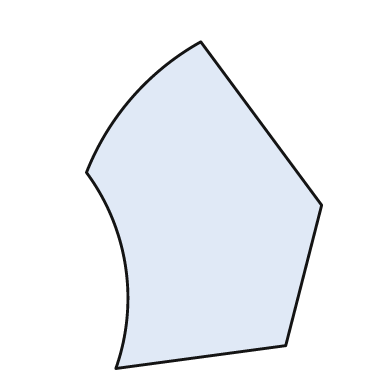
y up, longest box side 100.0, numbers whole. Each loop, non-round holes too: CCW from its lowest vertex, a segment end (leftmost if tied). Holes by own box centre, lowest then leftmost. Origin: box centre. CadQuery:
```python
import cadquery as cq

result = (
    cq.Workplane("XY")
    .moveTo(-27.0, -50.0)
    .lineTo(25.0, -43.0)
    .lineTo(36.0, 0.0)
    .lineTo(-1.0, 50.0)
    .threePointArc((-22.0, 33.0), (-36.0, 10.0))
    .threePointArc((-24.0, -19.0), (-27.0, -50.0))
    .close()
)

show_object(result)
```